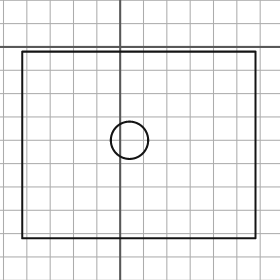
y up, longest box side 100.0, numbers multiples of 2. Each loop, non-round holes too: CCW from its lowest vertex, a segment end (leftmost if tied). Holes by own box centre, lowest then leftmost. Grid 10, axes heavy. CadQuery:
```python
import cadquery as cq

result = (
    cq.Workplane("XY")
    .moveTo(-42.0, -82.0)
    .lineTo(58.0, -82.0)
    .lineTo(58.0, -2.0)
    .lineTo(-42.0, -2.0)
    .close()
    .moveTo(4.0, -40.0)
    .circle(8.0)
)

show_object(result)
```